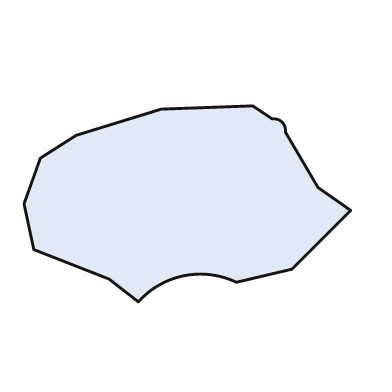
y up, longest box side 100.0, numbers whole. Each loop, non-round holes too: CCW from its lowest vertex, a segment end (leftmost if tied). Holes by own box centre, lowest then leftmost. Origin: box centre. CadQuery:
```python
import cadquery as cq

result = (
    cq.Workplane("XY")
    .moveTo(-15.0, -30.0)
    .threePointArc((-1.0, -22.0), (15.0, -24.0))
    .lineTo(32.0, -20.0)
    .lineTo(50.0, -2.0)
    .lineTo(40.0, 5.0)
    .lineTo(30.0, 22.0)
    .threePointArc((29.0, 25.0), (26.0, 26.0))
    .lineTo(20.0, 30.0)
    .lineTo(-8.0, 29.0)
    .lineTo(-34.0, 21.0)
    .lineTo(-45.0, 14.0)
    .lineTo(-50.0, 0.0)
    .lineTo(-47.0, -14.0)
    .lineTo(-24.0, -23.0)
    .close()
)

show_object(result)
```